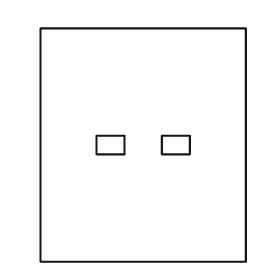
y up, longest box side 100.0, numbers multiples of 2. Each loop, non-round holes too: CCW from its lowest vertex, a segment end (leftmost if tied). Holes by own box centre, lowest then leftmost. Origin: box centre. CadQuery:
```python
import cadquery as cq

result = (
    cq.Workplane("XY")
    .moveTo(-44.0, -50.0)
    .lineTo(44.0, -50.0)
    .lineTo(44.0, 50.0)
    .lineTo(-44.0, 50.0)
    .close()
    .moveTo(-20.0, -4.0)
    .lineTo(-8.0, -4.0)
    .lineTo(-8.0, 4.0)
    .lineTo(-20.0, 4.0)
    .close()
    .moveTo(8.0, -4.0)
    .lineTo(20.0, -4.0)
    .lineTo(20.0, 4.0)
    .lineTo(8.0, 4.0)
    .close()
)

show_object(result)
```